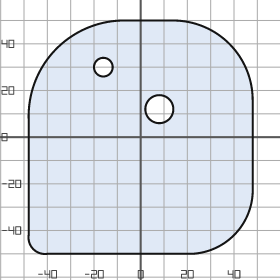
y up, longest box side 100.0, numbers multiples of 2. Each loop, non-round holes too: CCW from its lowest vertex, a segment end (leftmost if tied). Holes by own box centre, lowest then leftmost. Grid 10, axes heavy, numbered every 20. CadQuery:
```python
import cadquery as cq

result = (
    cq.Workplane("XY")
    .moveTo(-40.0, -50.0)
    .lineTo(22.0, -50.0)
    .threePointArc((40.0, -42.0), (48.0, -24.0))
    .lineTo(48.0, 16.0)
    .threePointArc((38.0, 40.0), (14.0, 50.0))
    .lineTo(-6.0, 50.0)
    .threePointArc((-36.0, 38.0), (-48.0, 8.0))
    .lineTo(-48.0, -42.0)
    .threePointArc((-46.0, -48.0), (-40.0, -50.0))
    .close()
    .moveTo(8.0, 12.0)
    .circle(6.0)
    .moveTo(-16.0, 30.0)
    .circle(4.0)
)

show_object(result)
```